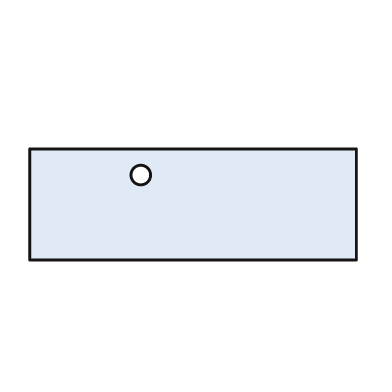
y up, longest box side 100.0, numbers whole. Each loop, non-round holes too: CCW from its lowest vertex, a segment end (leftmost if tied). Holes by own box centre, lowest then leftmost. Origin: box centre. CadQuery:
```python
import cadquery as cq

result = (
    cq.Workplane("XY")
    .moveTo(-50.0, -17.0)
    .lineTo(50.0, -17.0)
    .lineTo(50.0, 17.0)
    .lineTo(-50.0, 17.0)
    .close()
    .moveTo(-16.0, 9.0)
    .circle(3.0)
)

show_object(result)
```